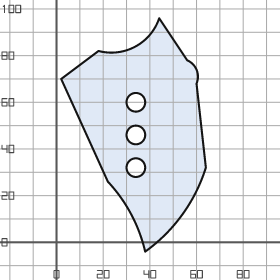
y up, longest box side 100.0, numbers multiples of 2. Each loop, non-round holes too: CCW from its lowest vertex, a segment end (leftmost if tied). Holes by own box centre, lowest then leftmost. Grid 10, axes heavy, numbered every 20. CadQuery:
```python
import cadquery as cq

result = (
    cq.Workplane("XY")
    .moveTo(38.0, -4.0)
    .threePointArc((54.0, 12.0), (64.0, 32.0))
    .lineTo(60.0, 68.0)
    .threePointArc((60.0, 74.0), (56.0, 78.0))
    .lineTo(44.0, 96.0)
    .threePointArc((34.0, 84.0), (18.0, 82.0))
    .lineTo(2.0, 70.0)
    .lineTo(22.0, 26.0)
    .threePointArc((32.0, 12.0), (38.0, -4.0))
    .close()
    .moveTo(34.0, 32.0)
    .circle(4.0)
    .moveTo(34.0, 46.0)
    .circle(4.0)
    .moveTo(34.0, 60.0)
    .circle(4.0)
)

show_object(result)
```